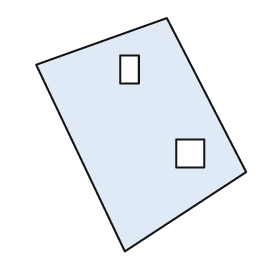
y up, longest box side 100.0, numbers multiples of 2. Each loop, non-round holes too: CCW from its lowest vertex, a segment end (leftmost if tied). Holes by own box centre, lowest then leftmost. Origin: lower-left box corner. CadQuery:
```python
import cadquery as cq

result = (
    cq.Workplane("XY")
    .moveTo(38.0, 0.0)
    .lineTo(90.0, 34.0)
    .lineTo(56.0, 100.0)
    .lineTo(0.0, 80.0)
    .close()
    .moveTo(60.0, 36.0)
    .lineTo(72.0, 36.0)
    .lineTo(72.0, 48.0)
    .lineTo(60.0, 48.0)
    .close()
    .moveTo(36.0, 72.0)
    .lineTo(44.0, 72.0)
    .lineTo(44.0, 84.0)
    .lineTo(36.0, 84.0)
    .close()
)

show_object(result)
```